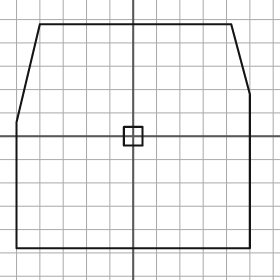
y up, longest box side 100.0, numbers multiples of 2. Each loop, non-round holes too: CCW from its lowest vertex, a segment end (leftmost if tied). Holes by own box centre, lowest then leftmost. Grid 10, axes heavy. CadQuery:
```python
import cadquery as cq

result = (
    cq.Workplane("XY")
    .moveTo(-50.0, -48.0)
    .lineTo(50.0, -48.0)
    .lineTo(50.0, 18.0)
    .lineTo(42.0, 48.0)
    .lineTo(-40.0, 48.0)
    .lineTo(-50.0, 6.0)
    .close()
    .moveTo(-4.0, -4.0)
    .lineTo(4.0, -4.0)
    .lineTo(4.0, 4.0)
    .lineTo(-4.0, 4.0)
    .close()
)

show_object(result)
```